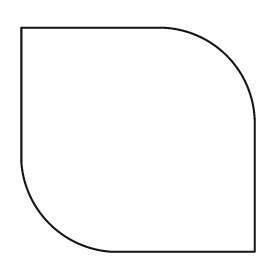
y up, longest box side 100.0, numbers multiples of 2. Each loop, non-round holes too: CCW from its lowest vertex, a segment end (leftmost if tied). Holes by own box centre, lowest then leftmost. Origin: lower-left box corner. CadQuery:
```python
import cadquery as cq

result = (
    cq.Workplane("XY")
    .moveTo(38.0, 0.0)
    .lineTo(100.0, 0.0)
    .lineTo(100.0, 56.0)
    .threePointArc((88.0, 84.0), (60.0, 96.0))
    .lineTo(0.0, 96.0)
    .lineTo(0.0, 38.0)
    .threePointArc((12.0, 12.0), (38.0, 0.0))
    .close()
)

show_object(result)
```